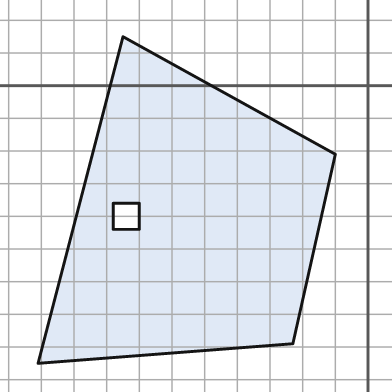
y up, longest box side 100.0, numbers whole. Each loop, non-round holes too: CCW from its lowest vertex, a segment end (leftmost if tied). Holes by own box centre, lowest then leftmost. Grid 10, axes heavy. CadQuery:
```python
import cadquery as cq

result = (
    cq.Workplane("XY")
    .moveTo(-101.0, -85.0)
    .lineTo(-23.0, -79.0)
    .lineTo(-10.0, -21.0)
    .lineTo(-75.0, 15.0)
    .close()
    .moveTo(-78.0, -44.0)
    .lineTo(-70.0, -44.0)
    .lineTo(-70.0, -36.0)
    .lineTo(-78.0, -36.0)
    .close()
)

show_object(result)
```